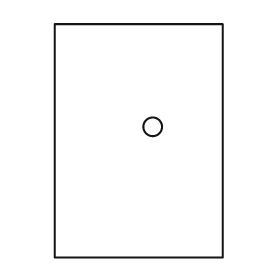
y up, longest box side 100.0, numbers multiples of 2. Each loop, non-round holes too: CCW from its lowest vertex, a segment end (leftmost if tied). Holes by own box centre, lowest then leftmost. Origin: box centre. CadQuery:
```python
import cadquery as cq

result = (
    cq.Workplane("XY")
    .moveTo(-36.0, -50.0)
    .lineTo(36.0, -50.0)
    .lineTo(36.0, 50.0)
    .lineTo(-36.0, 50.0)
    .close()
    .moveTo(6.0, 6.0)
    .circle(4.0)
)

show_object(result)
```